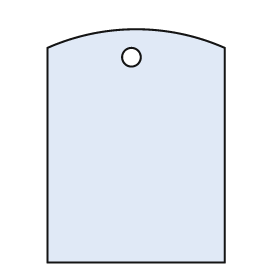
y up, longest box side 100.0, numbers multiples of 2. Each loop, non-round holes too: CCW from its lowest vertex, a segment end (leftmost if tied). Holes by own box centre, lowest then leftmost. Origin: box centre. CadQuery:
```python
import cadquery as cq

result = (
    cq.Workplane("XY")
    .moveTo(-38.0, -50.0)
    .lineTo(38.0, -50.0)
    .lineTo(38.0, 42.0)
    .threePointArc((0.0, 50.0), (-38.0, 42.0))
    .close()
    .moveTo(-2.0, 38.0)
    .circle(4.0)
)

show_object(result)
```